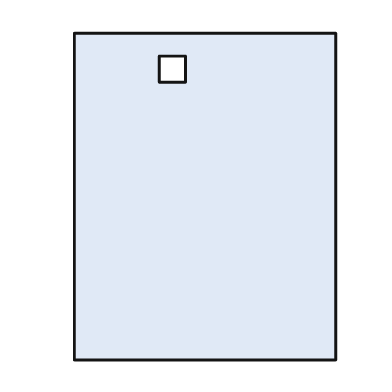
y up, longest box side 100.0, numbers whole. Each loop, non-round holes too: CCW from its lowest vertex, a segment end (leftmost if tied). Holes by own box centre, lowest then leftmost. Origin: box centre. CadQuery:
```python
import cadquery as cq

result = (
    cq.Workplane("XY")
    .moveTo(-40.0, -50.0)
    .lineTo(40.0, -50.0)
    .lineTo(40.0, 50.0)
    .lineTo(-40.0, 50.0)
    .close()
    .moveTo(-14.0, 35.0)
    .lineTo(-6.0, 35.0)
    .lineTo(-6.0, 43.0)
    .lineTo(-14.0, 43.0)
    .close()
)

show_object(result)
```